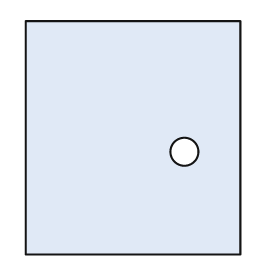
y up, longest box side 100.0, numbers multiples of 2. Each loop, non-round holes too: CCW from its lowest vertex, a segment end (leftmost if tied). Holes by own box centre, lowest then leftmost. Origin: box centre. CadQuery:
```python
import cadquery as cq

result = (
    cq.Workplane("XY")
    .moveTo(-46.0, -50.0)
    .lineTo(46.0, -50.0)
    .lineTo(46.0, 50.0)
    .lineTo(-46.0, 50.0)
    .close()
    .moveTo(22.0, -6.0)
    .circle(6.0)
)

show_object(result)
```